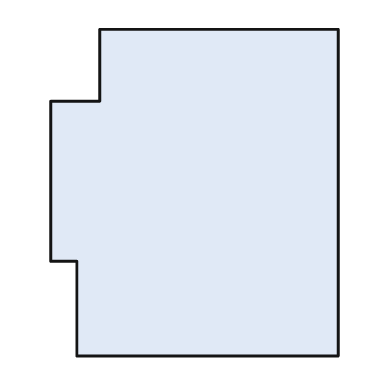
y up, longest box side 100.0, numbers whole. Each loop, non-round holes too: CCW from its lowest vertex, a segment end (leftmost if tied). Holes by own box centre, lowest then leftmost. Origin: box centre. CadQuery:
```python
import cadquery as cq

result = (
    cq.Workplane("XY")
    .moveTo(-36.0, -50.0)
    .lineTo(44.0, -50.0)
    .lineTo(44.0, 50.0)
    .lineTo(-29.0, 50.0)
    .lineTo(-29.0, 28.0)
    .lineTo(-44.0, 28.0)
    .lineTo(-44.0, -21.0)
    .lineTo(-36.0, -21.0)
    .close()
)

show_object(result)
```